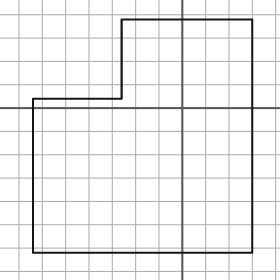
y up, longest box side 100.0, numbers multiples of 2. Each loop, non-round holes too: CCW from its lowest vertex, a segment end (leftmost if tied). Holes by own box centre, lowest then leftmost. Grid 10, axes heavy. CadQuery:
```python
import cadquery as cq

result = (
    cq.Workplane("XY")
    .moveTo(-64.0, -62.0)
    .lineTo(30.0, -62.0)
    .lineTo(30.0, 38.0)
    .lineTo(-26.0, 38.0)
    .lineTo(-26.0, 4.0)
    .lineTo(-64.0, 4.0)
    .close()
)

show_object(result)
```